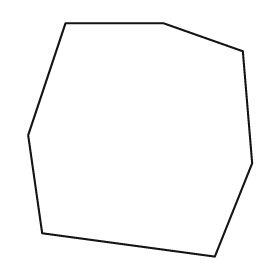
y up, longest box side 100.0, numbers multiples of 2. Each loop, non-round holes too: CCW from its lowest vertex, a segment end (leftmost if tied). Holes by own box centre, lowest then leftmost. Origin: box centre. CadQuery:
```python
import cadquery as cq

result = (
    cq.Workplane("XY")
    .moveTo(32.0, -50.0)
    .lineTo(48.0, -10.0)
    .lineTo(44.0, 38.0)
    .lineTo(10.0, 50.0)
    .lineTo(-32.0, 50.0)
    .lineTo(-48.0, 2.0)
    .lineTo(-42.0, -40.0)
    .close()
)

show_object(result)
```